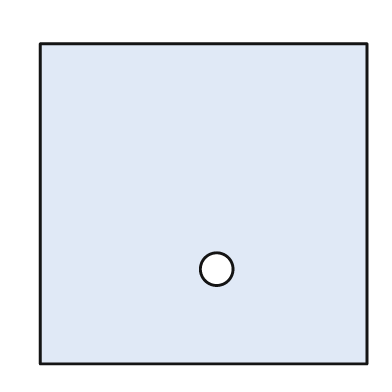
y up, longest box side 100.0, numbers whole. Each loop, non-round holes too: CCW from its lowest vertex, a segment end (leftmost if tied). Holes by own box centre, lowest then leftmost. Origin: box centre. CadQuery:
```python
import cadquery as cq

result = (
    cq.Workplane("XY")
    .moveTo(-50.0, -49.0)
    .lineTo(50.0, -49.0)
    .lineTo(50.0, 49.0)
    .lineTo(-50.0, 49.0)
    .close()
    .moveTo(4.0, -20.0)
    .circle(5.0)
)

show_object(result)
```